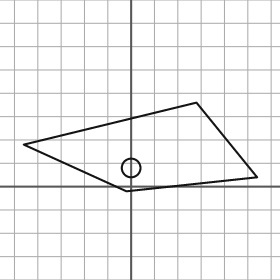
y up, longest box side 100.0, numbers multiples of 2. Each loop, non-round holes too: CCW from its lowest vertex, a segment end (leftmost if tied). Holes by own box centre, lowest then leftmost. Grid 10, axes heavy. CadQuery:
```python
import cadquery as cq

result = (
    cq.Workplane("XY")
    .moveTo(-2.0, -2.0)
    .lineTo(54.0, 4.0)
    .lineTo(28.0, 36.0)
    .lineTo(-46.0, 18.0)
    .close()
    .moveTo(0.0, 8.0)
    .circle(4.0)
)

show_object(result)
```